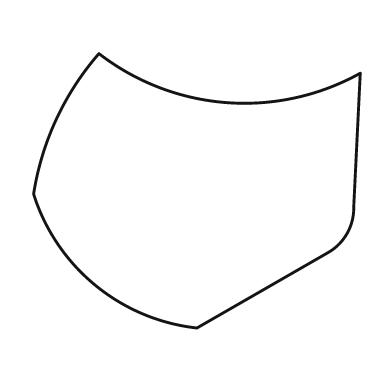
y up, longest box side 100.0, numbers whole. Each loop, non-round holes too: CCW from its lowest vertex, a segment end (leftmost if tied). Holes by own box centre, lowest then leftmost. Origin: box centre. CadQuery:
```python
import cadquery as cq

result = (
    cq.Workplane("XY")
    .moveTo(0.0, -42.0)
    .lineTo(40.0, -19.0)
    .threePointArc((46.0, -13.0), (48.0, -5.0))
    .lineTo(50.0, 36.0)
    .threePointArc((9.0, 27.0), (-30.0, 42.0))
    .threePointArc((-43.0, 22.0), (-50.0, -1.0))
    .threePointArc((-31.0, -29.0), (0.0, -42.0))
    .close()
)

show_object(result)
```